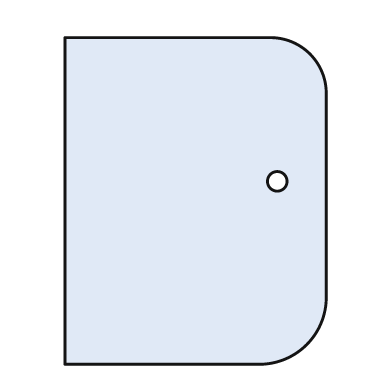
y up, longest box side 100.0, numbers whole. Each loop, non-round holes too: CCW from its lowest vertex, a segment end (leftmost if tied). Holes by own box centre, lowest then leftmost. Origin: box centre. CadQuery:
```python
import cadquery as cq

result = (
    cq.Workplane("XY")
    .moveTo(-40.0, -50.0)
    .lineTo(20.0, -50.0)
    .threePointArc((34.0, -44.0), (40.0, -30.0))
    .lineTo(40.0, 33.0)
    .threePointArc((35.0, 45.0), (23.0, 50.0))
    .lineTo(-40.0, 50.0)
    .close()
    .moveTo(25.0, 6.0)
    .circle(3.0)
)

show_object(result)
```